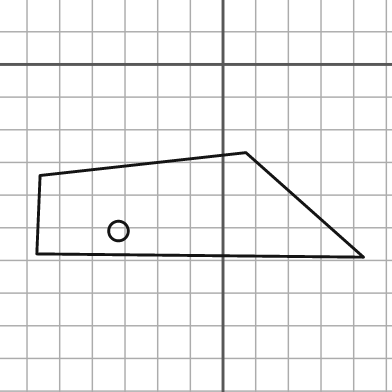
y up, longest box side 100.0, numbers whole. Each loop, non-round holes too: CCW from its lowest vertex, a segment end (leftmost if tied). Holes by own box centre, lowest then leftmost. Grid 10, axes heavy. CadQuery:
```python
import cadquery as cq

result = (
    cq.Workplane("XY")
    .moveTo(43.0, -59.0)
    .lineTo(7.0, -27.0)
    .lineTo(-56.0, -34.0)
    .lineTo(-57.0, -58.0)
    .close()
    .moveTo(-32.0, -51.0)
    .circle(3.0)
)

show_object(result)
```